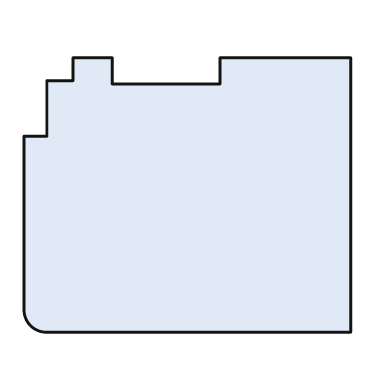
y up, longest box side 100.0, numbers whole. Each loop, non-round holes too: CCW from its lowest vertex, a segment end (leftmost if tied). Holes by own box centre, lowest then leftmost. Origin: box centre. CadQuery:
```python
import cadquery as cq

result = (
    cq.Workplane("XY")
    .moveTo(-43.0, -42.0)
    .lineTo(50.0, -42.0)
    .lineTo(50.0, 42.0)
    .lineTo(10.0, 42.0)
    .lineTo(10.0, 34.0)
    .lineTo(-23.0, 34.0)
    .lineTo(-23.0, 42.0)
    .lineTo(-35.0, 42.0)
    .lineTo(-35.0, 35.0)
    .lineTo(-43.0, 35.0)
    .lineTo(-43.0, 18.0)
    .lineTo(-50.0, 18.0)
    .lineTo(-50.0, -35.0)
    .threePointArc((-48.0, -40.0), (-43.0, -42.0))
    .close()
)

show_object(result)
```